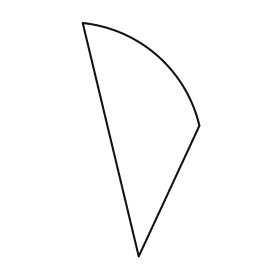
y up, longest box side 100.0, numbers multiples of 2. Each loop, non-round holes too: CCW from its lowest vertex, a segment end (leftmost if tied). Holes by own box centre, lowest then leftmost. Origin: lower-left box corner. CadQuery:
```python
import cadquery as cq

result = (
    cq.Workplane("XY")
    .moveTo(24.0, 0.0)
    .lineTo(50.0, 56.0)
    .threePointArc((32.0, 86.0), (0.0, 100.0))
    .close()
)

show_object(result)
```